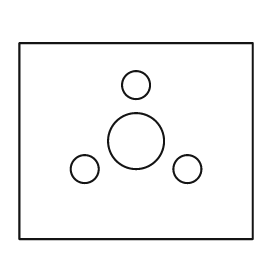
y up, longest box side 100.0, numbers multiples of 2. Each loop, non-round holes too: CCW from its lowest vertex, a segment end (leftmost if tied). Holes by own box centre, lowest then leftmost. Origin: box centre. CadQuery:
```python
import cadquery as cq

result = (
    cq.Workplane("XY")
    .moveTo(-50.0, -42.0)
    .lineTo(50.0, -42.0)
    .lineTo(50.0, 42.0)
    .lineTo(-50.0, 42.0)
    .close()
    .moveTo(-22.0, -12.0)
    .circle(6.0)
    .moveTo(22.0, -12.0)
    .circle(6.0)
    .moveTo(0.0, 0.0)
    .circle(12.0)
    .moveTo(0.0, 24.0)
    .circle(6.0)
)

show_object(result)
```